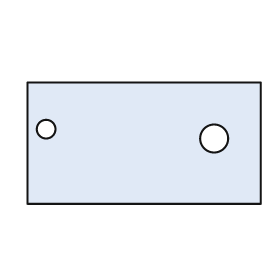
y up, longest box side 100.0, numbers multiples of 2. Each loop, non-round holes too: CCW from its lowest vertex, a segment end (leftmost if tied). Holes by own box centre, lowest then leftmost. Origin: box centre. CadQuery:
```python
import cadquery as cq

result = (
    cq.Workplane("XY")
    .moveTo(-50.0, -26.0)
    .lineTo(50.0, -26.0)
    .lineTo(50.0, 26.0)
    .lineTo(-50.0, 26.0)
    .close()
    .moveTo(30.0, 2.0)
    .circle(6.0)
    .moveTo(-42.0, 6.0)
    .circle(4.0)
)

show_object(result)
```